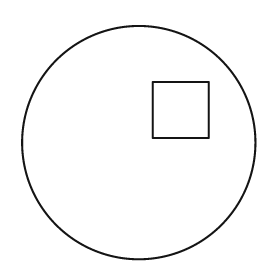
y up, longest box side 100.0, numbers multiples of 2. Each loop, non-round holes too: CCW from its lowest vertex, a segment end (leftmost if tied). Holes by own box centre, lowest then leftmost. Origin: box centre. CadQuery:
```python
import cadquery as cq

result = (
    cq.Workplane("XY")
    .moveTo(0.0, 0.0)
    .circle(50.0)
    .moveTo(6.0, 2.0)
    .lineTo(30.0, 2.0)
    .lineTo(30.0, 26.0)
    .lineTo(6.0, 26.0)
    .close()
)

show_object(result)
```